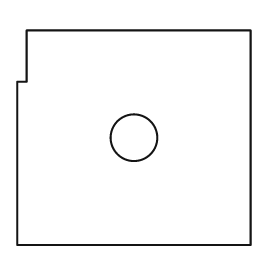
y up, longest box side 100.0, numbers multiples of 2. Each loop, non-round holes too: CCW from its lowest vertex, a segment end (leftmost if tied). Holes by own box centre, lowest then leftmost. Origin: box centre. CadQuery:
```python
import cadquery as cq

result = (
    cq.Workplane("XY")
    .moveTo(-50.0, -46.0)
    .lineTo(50.0, -46.0)
    .lineTo(50.0, 46.0)
    .lineTo(-46.0, 46.0)
    .lineTo(-46.0, 24.0)
    .lineTo(-50.0, 24.0)
    .close()
    .moveTo(0.0, 0.0)
    .circle(10.0)
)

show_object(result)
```